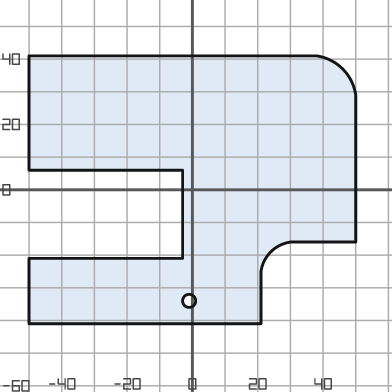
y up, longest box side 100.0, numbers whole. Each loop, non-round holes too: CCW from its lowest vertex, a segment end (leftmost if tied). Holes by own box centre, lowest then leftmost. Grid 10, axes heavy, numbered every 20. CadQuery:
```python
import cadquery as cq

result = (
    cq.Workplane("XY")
    .moveTo(-50.0, -41.0)
    .lineTo(21.0, -41.0)
    .lineTo(21.0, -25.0)
    .threePointArc((24.0, -19.0), (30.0, -16.0))
    .lineTo(50.0, -16.0)
    .lineTo(50.0, 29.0)
    .threePointArc((46.0, 37.0), (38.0, 41.0))
    .lineTo(-50.0, 41.0)
    .lineTo(-50.0, 6.0)
    .lineTo(-3.0, 6.0)
    .lineTo(-3.0, -21.0)
    .lineTo(-50.0, -21.0)
    .close()
    .moveTo(-1.0, -34.0)
    .circle(2.0)
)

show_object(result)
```